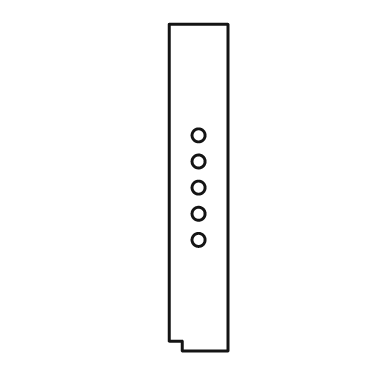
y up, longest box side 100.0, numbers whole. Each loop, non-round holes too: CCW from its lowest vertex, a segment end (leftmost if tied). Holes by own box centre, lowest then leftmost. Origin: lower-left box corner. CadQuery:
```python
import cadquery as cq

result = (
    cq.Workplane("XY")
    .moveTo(4.0, 0.0)
    .lineTo(18.0, 0.0)
    .lineTo(18.0, 100.0)
    .lineTo(0.0, 100.0)
    .lineTo(0.0, 3.0)
    .lineTo(4.0, 3.0)
    .close()
    .moveTo(9.0, 34.0)
    .circle(2.0)
    .moveTo(9.0, 42.0)
    .circle(2.0)
    .moveTo(9.0, 50.0)
    .circle(2.0)
    .moveTo(9.0, 58.0)
    .circle(2.0)
    .moveTo(9.0, 66.0)
    .circle(2.0)
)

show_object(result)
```